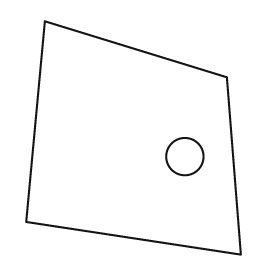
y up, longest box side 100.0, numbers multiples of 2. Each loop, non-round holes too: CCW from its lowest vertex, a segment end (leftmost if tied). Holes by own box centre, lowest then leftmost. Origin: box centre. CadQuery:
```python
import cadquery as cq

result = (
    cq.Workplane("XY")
    .moveTo(46.0, -50.0)
    .lineTo(40.0, 26.0)
    .lineTo(-38.0, 50.0)
    .lineTo(-46.0, -36.0)
    .close()
    .moveTo(22.0, -8.0)
    .circle(8.0)
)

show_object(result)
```